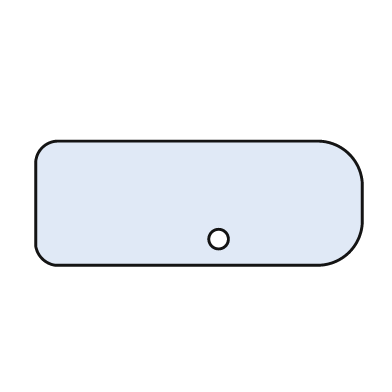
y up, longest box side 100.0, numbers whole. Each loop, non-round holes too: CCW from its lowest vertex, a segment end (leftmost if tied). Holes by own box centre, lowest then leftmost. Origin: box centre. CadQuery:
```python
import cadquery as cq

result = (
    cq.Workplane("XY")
    .moveTo(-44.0, -19.0)
    .lineTo(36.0, -19.0)
    .threePointArc((46.0, -15.0), (50.0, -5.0))
    .lineTo(50.0, 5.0)
    .threePointArc((46.0, 15.0), (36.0, 19.0))
    .lineTo(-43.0, 19.0)
    .threePointArc((-48.0, 17.0), (-50.0, 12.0))
    .lineTo(-50.0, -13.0)
    .threePointArc((-48.0, -17.0), (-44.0, -19.0))
    .close()
    .moveTo(6.0, -11.0)
    .circle(3.0)
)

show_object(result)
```